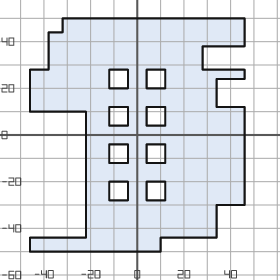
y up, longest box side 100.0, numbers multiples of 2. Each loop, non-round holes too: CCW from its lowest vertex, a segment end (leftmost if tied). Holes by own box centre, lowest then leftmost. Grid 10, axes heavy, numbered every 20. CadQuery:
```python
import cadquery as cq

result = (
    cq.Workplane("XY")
    .moveTo(-46.0, -50.0)
    .lineTo(10.0, -50.0)
    .lineTo(10.0, -44.0)
    .lineTo(34.0, -44.0)
    .lineTo(34.0, -30.0)
    .lineTo(46.0, -30.0)
    .lineTo(46.0, 12.0)
    .lineTo(34.0, 12.0)
    .lineTo(34.0, 24.0)
    .lineTo(46.0, 24.0)
    .lineTo(46.0, 28.0)
    .lineTo(28.0, 28.0)
    .lineTo(28.0, 38.0)
    .lineTo(46.0, 38.0)
    .lineTo(46.0, 50.0)
    .lineTo(-32.0, 50.0)
    .lineTo(-32.0, 44.0)
    .lineTo(-38.0, 44.0)
    .lineTo(-38.0, 28.0)
    .lineTo(-46.0, 28.0)
    .lineTo(-46.0, 10.0)
    .lineTo(-22.0, 10.0)
    .lineTo(-22.0, -44.0)
    .lineTo(-46.0, -44.0)
    .close()
    .moveTo(-12.0, -28.0)
    .lineTo(-4.0, -28.0)
    .lineTo(-4.0, -20.0)
    .lineTo(-12.0, -20.0)
    .close()
    .moveTo(4.0, -28.0)
    .lineTo(12.0, -28.0)
    .lineTo(12.0, -20.0)
    .lineTo(4.0, -20.0)
    .close()
    .moveTo(-12.0, -12.0)
    .lineTo(-4.0, -12.0)
    .lineTo(-4.0, -4.0)
    .lineTo(-12.0, -4.0)
    .close()
    .moveTo(4.0, -12.0)
    .lineTo(12.0, -12.0)
    .lineTo(12.0, -4.0)
    .lineTo(4.0, -4.0)
    .close()
    .moveTo(-12.0, 4.0)
    .lineTo(-4.0, 4.0)
    .lineTo(-4.0, 12.0)
    .lineTo(-12.0, 12.0)
    .close()
    .moveTo(4.0, 4.0)
    .lineTo(12.0, 4.0)
    .lineTo(12.0, 12.0)
    .lineTo(4.0, 12.0)
    .close()
    .moveTo(-12.0, 20.0)
    .lineTo(-4.0, 20.0)
    .lineTo(-4.0, 28.0)
    .lineTo(-12.0, 28.0)
    .close()
    .moveTo(4.0, 20.0)
    .lineTo(12.0, 20.0)
    .lineTo(12.0, 28.0)
    .lineTo(4.0, 28.0)
    .close()
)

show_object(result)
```